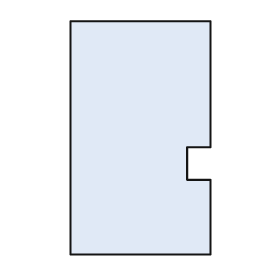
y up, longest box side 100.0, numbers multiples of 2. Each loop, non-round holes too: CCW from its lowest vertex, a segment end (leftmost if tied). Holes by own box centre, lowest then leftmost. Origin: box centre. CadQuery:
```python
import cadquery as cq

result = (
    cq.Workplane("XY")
    .moveTo(-30.0, -50.0)
    .lineTo(30.0, -50.0)
    .lineTo(30.0, -18.0)
    .lineTo(20.0, -18.0)
    .lineTo(20.0, -4.0)
    .lineTo(30.0, -4.0)
    .lineTo(30.0, 50.0)
    .lineTo(-30.0, 50.0)
    .close()
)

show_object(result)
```